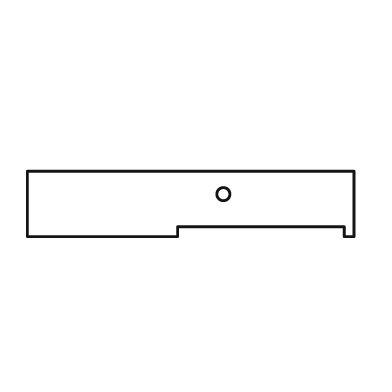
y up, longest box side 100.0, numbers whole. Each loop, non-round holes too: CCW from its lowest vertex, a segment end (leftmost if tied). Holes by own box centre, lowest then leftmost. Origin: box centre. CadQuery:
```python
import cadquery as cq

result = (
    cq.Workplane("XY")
    .moveTo(-50.0, -10.0)
    .lineTo(-4.0, -10.0)
    .lineTo(-4.0, -7.0)
    .lineTo(47.0, -7.0)
    .lineTo(47.0, -10.0)
    .lineTo(50.0, -10.0)
    .lineTo(50.0, 10.0)
    .lineTo(-50.0, 10.0)
    .close()
    .moveTo(10.0, 3.0)
    .circle(2.0)
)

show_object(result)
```